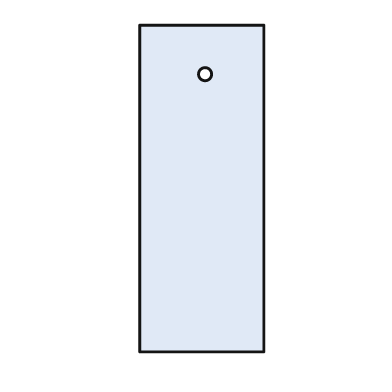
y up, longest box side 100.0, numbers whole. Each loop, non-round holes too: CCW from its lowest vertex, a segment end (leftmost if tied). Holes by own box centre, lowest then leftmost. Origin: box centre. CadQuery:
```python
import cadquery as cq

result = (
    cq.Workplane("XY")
    .moveTo(-19.0, -50.0)
    .lineTo(19.0, -50.0)
    .lineTo(19.0, 50.0)
    .lineTo(-19.0, 50.0)
    .close()
    .moveTo(1.0, 35.0)
    .circle(2.0)
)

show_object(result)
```